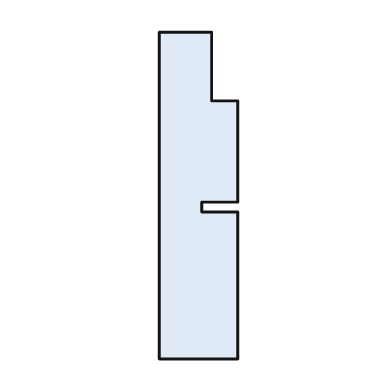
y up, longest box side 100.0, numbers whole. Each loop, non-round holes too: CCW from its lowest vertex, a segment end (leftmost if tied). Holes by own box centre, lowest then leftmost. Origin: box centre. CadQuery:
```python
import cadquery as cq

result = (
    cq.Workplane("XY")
    .moveTo(-12.0, -50.0)
    .lineTo(12.0, -50.0)
    .lineTo(12.0, -5.0)
    .lineTo(1.0, -5.0)
    .lineTo(1.0, -2.0)
    .lineTo(12.0, -2.0)
    .lineTo(12.0, 29.0)
    .lineTo(4.0, 29.0)
    .lineTo(4.0, 50.0)
    .lineTo(-12.0, 50.0)
    .close()
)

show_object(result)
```